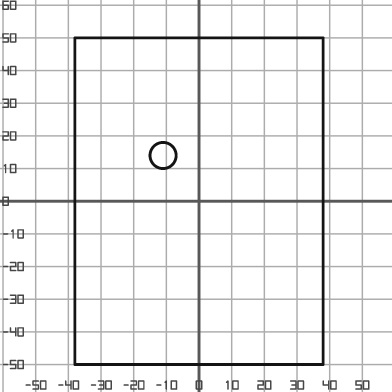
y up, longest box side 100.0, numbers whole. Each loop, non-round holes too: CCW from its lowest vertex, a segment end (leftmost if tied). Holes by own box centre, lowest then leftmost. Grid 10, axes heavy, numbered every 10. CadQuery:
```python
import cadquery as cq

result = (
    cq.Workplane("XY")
    .moveTo(-38.0, -50.0)
    .lineTo(38.0, -50.0)
    .lineTo(38.0, 50.0)
    .lineTo(-38.0, 50.0)
    .close()
    .moveTo(-11.0, 14.0)
    .circle(4.0)
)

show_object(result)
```